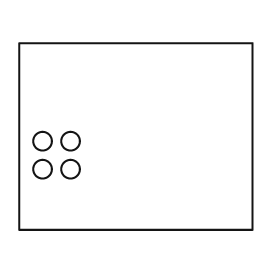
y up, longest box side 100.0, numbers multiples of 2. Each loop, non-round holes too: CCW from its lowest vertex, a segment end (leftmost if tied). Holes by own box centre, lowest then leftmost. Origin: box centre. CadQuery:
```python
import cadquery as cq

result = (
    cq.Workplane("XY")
    .moveTo(-50.0, -40.0)
    .lineTo(50.0, -40.0)
    .lineTo(50.0, 40.0)
    .lineTo(-50.0, 40.0)
    .close()
    .moveTo(-40.0, -14.0)
    .circle(4.0)
    .moveTo(-28.0, -14.0)
    .circle(4.0)
    .moveTo(-40.0, -2.0)
    .circle(4.0)
    .moveTo(-28.0, -2.0)
    .circle(4.0)
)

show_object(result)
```